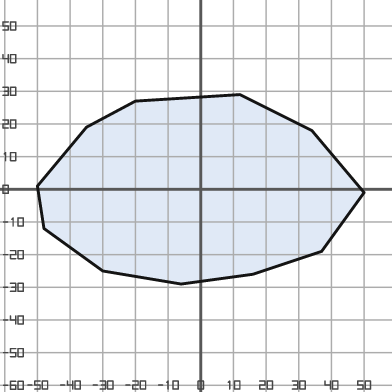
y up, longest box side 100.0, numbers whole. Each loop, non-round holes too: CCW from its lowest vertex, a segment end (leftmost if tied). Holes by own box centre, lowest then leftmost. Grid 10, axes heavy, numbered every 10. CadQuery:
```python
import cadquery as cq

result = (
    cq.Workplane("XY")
    .moveTo(-6.0, -29.0)
    .lineTo(16.0, -26.0)
    .lineTo(37.0, -19.0)
    .lineTo(50.0, -1.0)
    .lineTo(34.0, 18.0)
    .lineTo(12.0, 29.0)
    .lineTo(-20.0, 27.0)
    .lineTo(-35.0, 19.0)
    .lineTo(-50.0, 1.0)
    .lineTo(-48.0, -12.0)
    .lineTo(-30.0, -25.0)
    .close()
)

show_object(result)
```